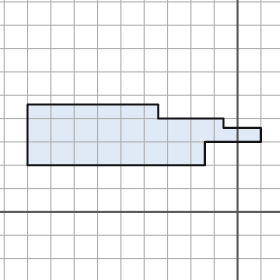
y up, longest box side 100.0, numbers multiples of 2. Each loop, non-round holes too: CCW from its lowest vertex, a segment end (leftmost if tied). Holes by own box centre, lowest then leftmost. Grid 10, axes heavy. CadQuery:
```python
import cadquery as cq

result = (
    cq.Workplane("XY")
    .moveTo(-90.0, 20.0)
    .lineTo(-14.0, 20.0)
    .lineTo(-14.0, 30.0)
    .lineTo(10.0, 30.0)
    .lineTo(10.0, 36.0)
    .lineTo(-6.0, 36.0)
    .lineTo(-6.0, 40.0)
    .lineTo(-34.0, 40.0)
    .lineTo(-34.0, 46.0)
    .lineTo(-90.0, 46.0)
    .close()
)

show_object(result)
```